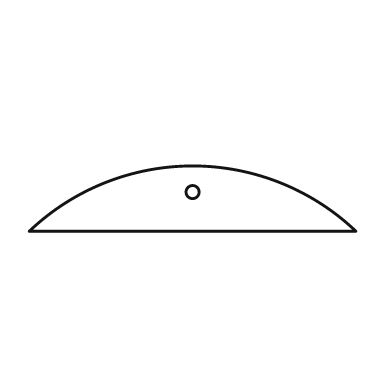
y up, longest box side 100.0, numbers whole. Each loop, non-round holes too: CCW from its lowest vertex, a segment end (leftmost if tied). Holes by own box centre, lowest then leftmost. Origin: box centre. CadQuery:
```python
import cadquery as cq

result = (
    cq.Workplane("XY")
    .moveTo(-50.0, -10.0)
    .lineTo(50.0, -10.0)
    .threePointArc((0.0, 10.0), (-50.0, -10.0))
    .close()
    .moveTo(0.0, 2.0)
    .circle(2.0)
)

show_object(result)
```